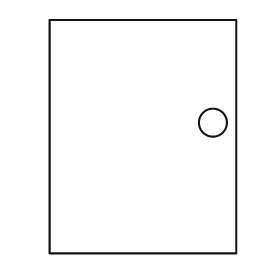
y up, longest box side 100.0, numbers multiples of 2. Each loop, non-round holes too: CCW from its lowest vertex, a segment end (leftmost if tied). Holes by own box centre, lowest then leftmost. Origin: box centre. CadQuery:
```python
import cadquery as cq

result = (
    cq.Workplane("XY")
    .moveTo(-40.0, -50.0)
    .lineTo(40.0, -50.0)
    .lineTo(40.0, 50.0)
    .lineTo(-40.0, 50.0)
    .close()
    .moveTo(30.0, 6.0)
    .circle(6.0)
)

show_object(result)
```